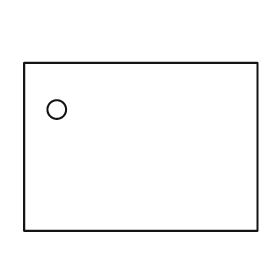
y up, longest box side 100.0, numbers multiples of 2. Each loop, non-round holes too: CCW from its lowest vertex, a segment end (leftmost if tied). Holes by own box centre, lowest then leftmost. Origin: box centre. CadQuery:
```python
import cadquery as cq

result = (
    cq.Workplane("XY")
    .moveTo(-50.0, -36.0)
    .lineTo(50.0, -36.0)
    .lineTo(50.0, 36.0)
    .lineTo(-50.0, 36.0)
    .close()
    .moveTo(-36.0, 16.0)
    .circle(4.0)
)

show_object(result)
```